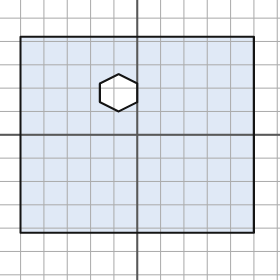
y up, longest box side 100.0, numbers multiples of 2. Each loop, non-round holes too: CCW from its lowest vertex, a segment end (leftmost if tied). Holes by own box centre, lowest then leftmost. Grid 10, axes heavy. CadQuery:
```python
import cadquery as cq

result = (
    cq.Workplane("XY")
    .moveTo(-50.0, -42.0)
    .lineTo(50.0, -42.0)
    .lineTo(50.0, 42.0)
    .lineTo(-50.0, 42.0)
    .close()
    .moveTo(-8.0, 10.0)
    .lineTo(0.0, 14.0)
    .lineTo(0.0, 22.0)
    .lineTo(-8.0, 26.0)
    .lineTo(-16.0, 22.0)
    .lineTo(-16.0, 14.0)
    .close()
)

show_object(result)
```